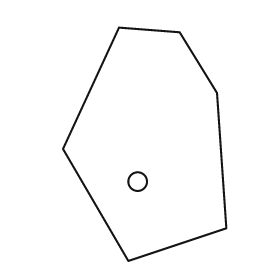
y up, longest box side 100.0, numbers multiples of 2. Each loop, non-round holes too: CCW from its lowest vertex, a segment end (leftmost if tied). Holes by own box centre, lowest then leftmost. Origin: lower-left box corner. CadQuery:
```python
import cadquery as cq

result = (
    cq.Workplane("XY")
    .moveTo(28.0, 0.0)
    .lineTo(70.0, 14.0)
    .lineTo(66.0, 72.0)
    .lineTo(50.0, 98.0)
    .lineTo(24.0, 100.0)
    .lineTo(0.0, 48.0)
    .close()
    .moveTo(32.0, 34.0)
    .circle(4.0)
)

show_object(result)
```